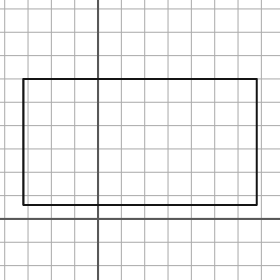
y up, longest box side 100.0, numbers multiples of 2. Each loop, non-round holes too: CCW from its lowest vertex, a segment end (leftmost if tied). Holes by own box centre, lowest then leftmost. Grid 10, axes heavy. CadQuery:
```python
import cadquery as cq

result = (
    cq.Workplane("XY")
    .moveTo(-32.0, 6.0)
    .lineTo(68.0, 6.0)
    .lineTo(68.0, 60.0)
    .lineTo(-32.0, 60.0)
    .close()
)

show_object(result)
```